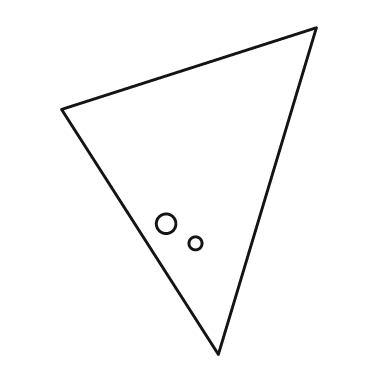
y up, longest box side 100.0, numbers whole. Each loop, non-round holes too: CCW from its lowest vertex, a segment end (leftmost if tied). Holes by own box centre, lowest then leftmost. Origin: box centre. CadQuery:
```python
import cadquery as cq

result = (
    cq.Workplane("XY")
    .moveTo(9.0, -50.0)
    .lineTo(39.0, 50.0)
    .lineTo(-39.0, 25.0)
    .close()
    .moveTo(2.0, -16.0)
    .circle(2.0)
    .moveTo(-7.0, -10.0)
    .circle(3.0)
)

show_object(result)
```